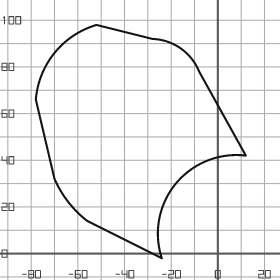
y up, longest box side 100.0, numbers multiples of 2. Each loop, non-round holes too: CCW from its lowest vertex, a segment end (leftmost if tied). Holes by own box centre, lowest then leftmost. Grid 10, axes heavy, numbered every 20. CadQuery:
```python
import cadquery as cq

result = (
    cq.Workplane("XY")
    .moveTo(-24.0, -2.0)
    .threePointArc((-18.0, 30.0), (12.0, 42.0))
    .lineTo(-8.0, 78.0)
    .threePointArc((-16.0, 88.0), (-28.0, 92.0))
    .lineTo(-52.0, 98.0)
    .threePointArc((-70.0, 86.0), (-78.0, 66.0))
    .lineTo(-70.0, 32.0)
    .threePointArc((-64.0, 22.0), (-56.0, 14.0))
    .close()
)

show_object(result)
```